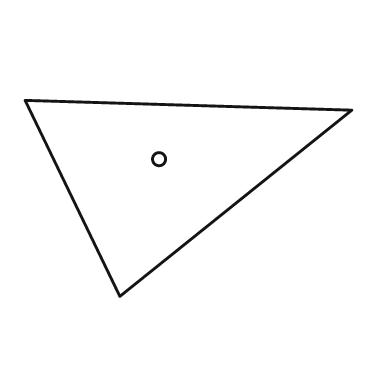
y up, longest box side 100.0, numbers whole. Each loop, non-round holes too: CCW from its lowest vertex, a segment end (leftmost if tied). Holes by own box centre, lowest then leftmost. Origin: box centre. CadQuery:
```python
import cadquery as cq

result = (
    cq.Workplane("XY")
    .moveTo(-21.0, -30.0)
    .lineTo(50.0, 27.0)
    .lineTo(-50.0, 30.0)
    .close()
    .moveTo(-9.0, 12.0)
    .circle(2.0)
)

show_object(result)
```